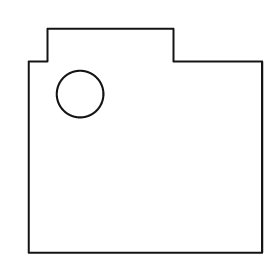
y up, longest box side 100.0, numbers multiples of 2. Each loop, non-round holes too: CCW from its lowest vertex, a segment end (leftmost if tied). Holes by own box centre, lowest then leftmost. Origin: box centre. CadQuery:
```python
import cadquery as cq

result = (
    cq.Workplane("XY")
    .moveTo(-50.0, -48.0)
    .lineTo(50.0, -48.0)
    .lineTo(50.0, 34.0)
    .lineTo(12.0, 34.0)
    .lineTo(12.0, 48.0)
    .lineTo(-42.0, 48.0)
    .lineTo(-42.0, 34.0)
    .lineTo(-50.0, 34.0)
    .close()
    .moveTo(-28.0, 20.0)
    .circle(10.0)
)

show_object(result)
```